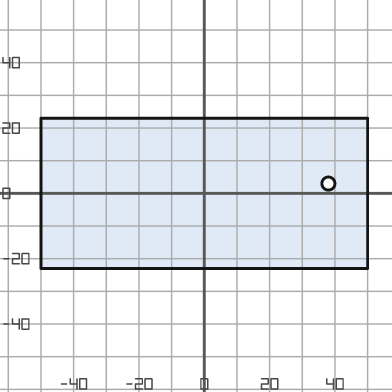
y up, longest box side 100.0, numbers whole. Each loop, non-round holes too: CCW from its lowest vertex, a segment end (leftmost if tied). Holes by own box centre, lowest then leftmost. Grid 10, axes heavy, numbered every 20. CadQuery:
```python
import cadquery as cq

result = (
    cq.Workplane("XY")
    .moveTo(-50.0, -23.0)
    .lineTo(50.0, -23.0)
    .lineTo(50.0, 23.0)
    .lineTo(-50.0, 23.0)
    .close()
    .moveTo(38.0, 3.0)
    .circle(2.0)
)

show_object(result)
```